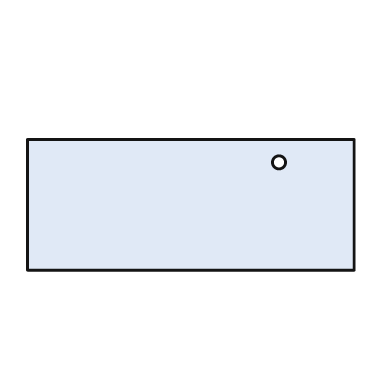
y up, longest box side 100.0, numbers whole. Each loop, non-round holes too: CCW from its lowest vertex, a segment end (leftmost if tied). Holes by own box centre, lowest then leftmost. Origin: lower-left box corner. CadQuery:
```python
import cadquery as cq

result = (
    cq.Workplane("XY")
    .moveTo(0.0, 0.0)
    .lineTo(100.0, 0.0)
    .lineTo(100.0, 40.0)
    .lineTo(0.0, 40.0)
    .close()
    .moveTo(77.0, 33.0)
    .circle(2.0)
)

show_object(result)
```